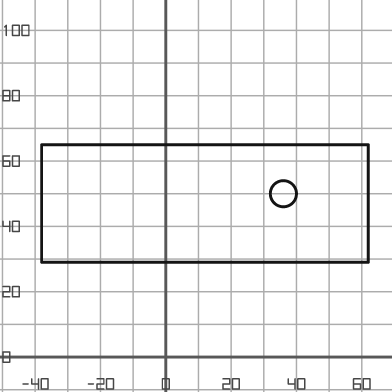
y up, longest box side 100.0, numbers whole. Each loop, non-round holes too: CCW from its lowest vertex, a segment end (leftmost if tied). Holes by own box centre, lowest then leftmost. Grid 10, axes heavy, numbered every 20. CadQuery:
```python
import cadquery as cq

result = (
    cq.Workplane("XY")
    .moveTo(-38.0, 29.0)
    .lineTo(62.0, 29.0)
    .lineTo(62.0, 65.0)
    .lineTo(-38.0, 65.0)
    .close()
    .moveTo(36.0, 50.0)
    .circle(4.0)
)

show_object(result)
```